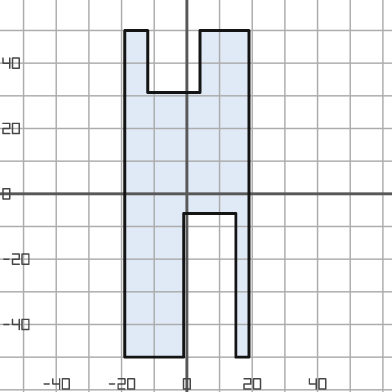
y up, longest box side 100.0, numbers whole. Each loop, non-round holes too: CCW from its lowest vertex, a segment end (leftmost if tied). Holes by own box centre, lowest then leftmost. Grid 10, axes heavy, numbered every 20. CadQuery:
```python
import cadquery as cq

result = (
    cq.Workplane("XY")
    .moveTo(-19.0, -50.0)
    .lineTo(-1.0, -50.0)
    .lineTo(-1.0, -6.0)
    .lineTo(15.0, -6.0)
    .lineTo(15.0, -50.0)
    .lineTo(19.0, -50.0)
    .lineTo(19.0, 50.0)
    .lineTo(4.0, 50.0)
    .lineTo(4.0, 31.0)
    .lineTo(-12.0, 31.0)
    .lineTo(-12.0, 50.0)
    .lineTo(-19.0, 50.0)
    .close()
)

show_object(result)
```